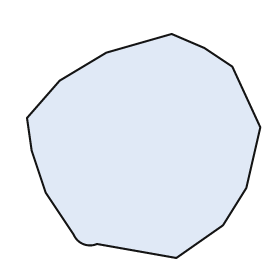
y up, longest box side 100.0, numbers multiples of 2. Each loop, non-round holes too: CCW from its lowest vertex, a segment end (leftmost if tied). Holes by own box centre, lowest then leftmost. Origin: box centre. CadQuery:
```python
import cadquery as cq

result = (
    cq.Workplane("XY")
    .moveTo(14.0, -48.0)
    .lineTo(34.0, -34.0)
    .lineTo(44.0, -18.0)
    .lineTo(50.0, 8.0)
    .lineTo(38.0, 34.0)
    .lineTo(26.0, 42.0)
    .lineTo(12.0, 48.0)
    .lineTo(-16.0, 40.0)
    .lineTo(-36.0, 28.0)
    .lineTo(-50.0, 12.0)
    .lineTo(-48.0, -2.0)
    .lineTo(-42.0, -20.0)
    .lineTo(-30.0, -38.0)
    .threePointArc((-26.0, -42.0), (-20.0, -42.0))
    .close()
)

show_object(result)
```